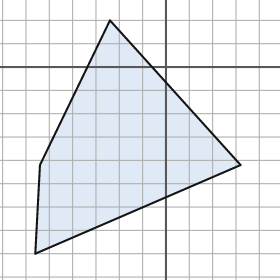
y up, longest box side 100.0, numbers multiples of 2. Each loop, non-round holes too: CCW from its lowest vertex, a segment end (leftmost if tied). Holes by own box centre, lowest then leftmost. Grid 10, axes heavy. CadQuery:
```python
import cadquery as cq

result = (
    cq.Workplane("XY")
    .moveTo(-56.0, -80.0)
    .lineTo(32.0, -42.0)
    .lineTo(-24.0, 20.0)
    .lineTo(-54.0, -42.0)
    .close()
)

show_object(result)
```